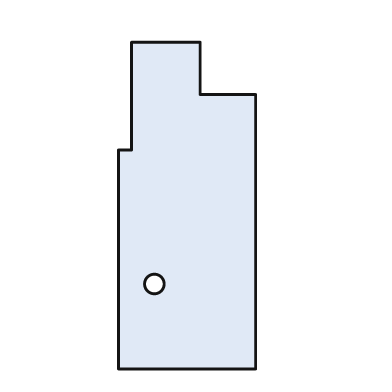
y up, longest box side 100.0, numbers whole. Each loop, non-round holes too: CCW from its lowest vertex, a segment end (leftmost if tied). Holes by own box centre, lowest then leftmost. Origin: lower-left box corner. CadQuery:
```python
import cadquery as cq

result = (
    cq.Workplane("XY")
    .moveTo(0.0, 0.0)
    .lineTo(42.0, 0.0)
    .lineTo(42.0, 84.0)
    .lineTo(25.0, 84.0)
    .lineTo(25.0, 100.0)
    .lineTo(4.0, 100.0)
    .lineTo(4.0, 67.0)
    .lineTo(0.0, 67.0)
    .close()
    .moveTo(11.0, 26.0)
    .circle(3.0)
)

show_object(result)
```